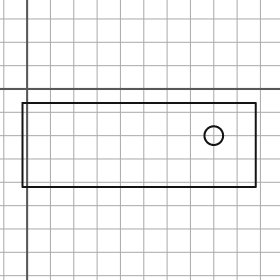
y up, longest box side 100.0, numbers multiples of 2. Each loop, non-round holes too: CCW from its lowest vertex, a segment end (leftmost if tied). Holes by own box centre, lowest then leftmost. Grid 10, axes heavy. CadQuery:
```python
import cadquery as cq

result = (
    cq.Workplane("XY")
    .moveTo(-2.0, -42.0)
    .lineTo(98.0, -42.0)
    .lineTo(98.0, -6.0)
    .lineTo(-2.0, -6.0)
    .close()
    .moveTo(80.0, -20.0)
    .circle(4.0)
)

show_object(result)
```